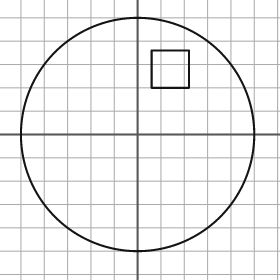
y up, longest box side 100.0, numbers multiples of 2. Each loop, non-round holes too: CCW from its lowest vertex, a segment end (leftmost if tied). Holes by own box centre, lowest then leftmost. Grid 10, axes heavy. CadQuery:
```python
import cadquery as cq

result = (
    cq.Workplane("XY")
    .moveTo(0.0, 0.0)
    .circle(50.0)
    .moveTo(6.0, 20.0)
    .lineTo(22.0, 20.0)
    .lineTo(22.0, 36.0)
    .lineTo(6.0, 36.0)
    .close()
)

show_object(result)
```